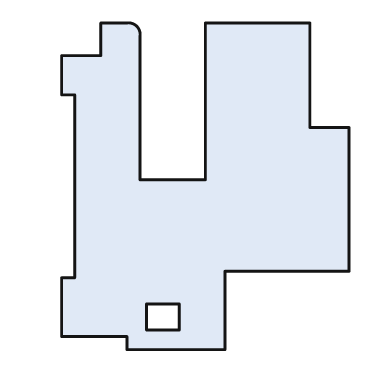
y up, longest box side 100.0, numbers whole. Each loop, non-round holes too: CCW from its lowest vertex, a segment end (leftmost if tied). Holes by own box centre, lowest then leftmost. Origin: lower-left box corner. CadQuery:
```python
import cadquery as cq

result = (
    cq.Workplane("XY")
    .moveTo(20.0, 0.0)
    .lineTo(50.0, 0.0)
    .lineTo(50.0, 24.0)
    .lineTo(88.0, 24.0)
    .lineTo(88.0, 68.0)
    .lineTo(76.0, 68.0)
    .lineTo(76.0, 100.0)
    .lineTo(44.0, 100.0)
    .lineTo(44.0, 52.0)
    .lineTo(24.0, 52.0)
    .lineTo(24.0, 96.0)
    .threePointArc((23.0, 99.0), (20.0, 100.0))
    .lineTo(12.0, 100.0)
    .lineTo(12.0, 90.0)
    .lineTo(0.0, 90.0)
    .lineTo(0.0, 78.0)
    .lineTo(4.0, 78.0)
    .lineTo(4.0, 22.0)
    .lineTo(0.0, 22.0)
    .lineTo(0.0, 4.0)
    .lineTo(20.0, 4.0)
    .close()
    .moveTo(26.0, 6.0)
    .lineTo(36.0, 6.0)
    .lineTo(36.0, 14.0)
    .lineTo(26.0, 14.0)
    .close()
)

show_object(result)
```